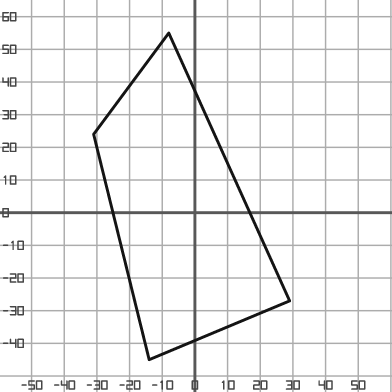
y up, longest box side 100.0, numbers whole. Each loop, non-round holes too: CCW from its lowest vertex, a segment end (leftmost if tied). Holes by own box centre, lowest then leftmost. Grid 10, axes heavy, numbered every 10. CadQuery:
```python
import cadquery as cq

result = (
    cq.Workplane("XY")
    .moveTo(-14.0, -45.0)
    .lineTo(29.0, -27.0)
    .lineTo(-8.0, 55.0)
    .lineTo(-31.0, 24.0)
    .close()
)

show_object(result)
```